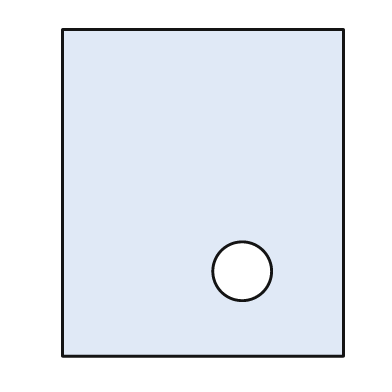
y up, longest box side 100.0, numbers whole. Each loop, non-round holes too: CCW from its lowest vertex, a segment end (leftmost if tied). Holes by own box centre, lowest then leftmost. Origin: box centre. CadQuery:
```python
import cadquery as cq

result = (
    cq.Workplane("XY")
    .moveTo(-43.0, -50.0)
    .lineTo(43.0, -50.0)
    .lineTo(43.0, 50.0)
    .lineTo(-43.0, 50.0)
    .close()
    .moveTo(12.0, -24.0)
    .circle(9.0)
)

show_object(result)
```